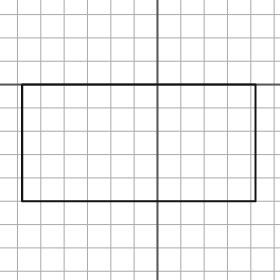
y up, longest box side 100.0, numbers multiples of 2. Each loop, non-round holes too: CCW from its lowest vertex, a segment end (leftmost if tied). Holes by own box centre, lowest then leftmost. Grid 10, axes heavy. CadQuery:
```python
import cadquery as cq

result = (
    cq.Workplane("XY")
    .moveTo(-58.0, -50.0)
    .lineTo(42.0, -50.0)
    .lineTo(42.0, 0.0)
    .lineTo(-58.0, 0.0)
    .close()
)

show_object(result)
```